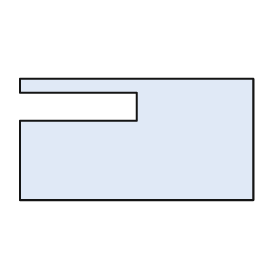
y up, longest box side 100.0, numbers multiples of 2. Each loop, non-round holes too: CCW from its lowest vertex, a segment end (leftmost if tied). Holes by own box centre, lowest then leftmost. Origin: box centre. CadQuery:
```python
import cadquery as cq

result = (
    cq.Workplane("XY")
    .moveTo(-50.0, -26.0)
    .lineTo(50.0, -26.0)
    .lineTo(50.0, 26.0)
    .lineTo(-50.0, 26.0)
    .lineTo(-50.0, 20.0)
    .lineTo(0.0, 20.0)
    .lineTo(0.0, 8.0)
    .lineTo(-50.0, 8.0)
    .close()
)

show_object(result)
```